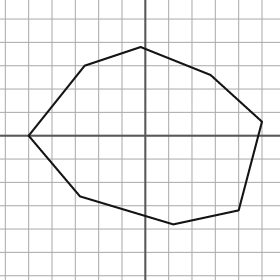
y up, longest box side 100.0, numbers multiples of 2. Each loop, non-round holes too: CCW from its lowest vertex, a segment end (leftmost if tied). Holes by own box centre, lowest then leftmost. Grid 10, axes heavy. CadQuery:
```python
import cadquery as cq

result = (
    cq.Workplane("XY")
    .moveTo(12.0, -38.0)
    .lineTo(40.0, -32.0)
    .lineTo(50.0, 6.0)
    .lineTo(28.0, 26.0)
    .lineTo(-2.0, 38.0)
    .lineTo(-26.0, 30.0)
    .lineTo(-50.0, 0.0)
    .lineTo(-28.0, -26.0)
    .close()
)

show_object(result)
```